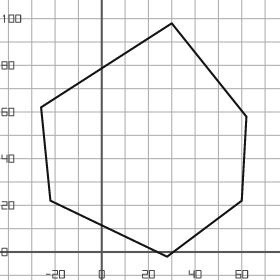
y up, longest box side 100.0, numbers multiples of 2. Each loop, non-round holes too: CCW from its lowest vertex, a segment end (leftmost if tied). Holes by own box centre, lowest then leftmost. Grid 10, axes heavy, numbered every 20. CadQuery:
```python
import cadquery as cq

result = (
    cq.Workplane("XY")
    .moveTo(28.0, -2.0)
    .lineTo(60.0, 22.0)
    .lineTo(62.0, 58.0)
    .lineTo(30.0, 98.0)
    .lineTo(-26.0, 62.0)
    .lineTo(-22.0, 22.0)
    .close()
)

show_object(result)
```